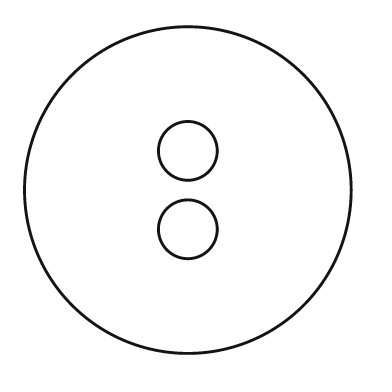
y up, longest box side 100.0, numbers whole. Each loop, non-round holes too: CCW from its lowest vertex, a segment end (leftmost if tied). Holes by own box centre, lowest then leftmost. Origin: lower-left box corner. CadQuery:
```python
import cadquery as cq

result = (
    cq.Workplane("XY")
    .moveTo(50.0, 50.0)
    .circle(50.0)
    .moveTo(50.0, 38.0)
    .circle(9.0)
    .moveTo(50.0, 62.0)
    .circle(9.0)
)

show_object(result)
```